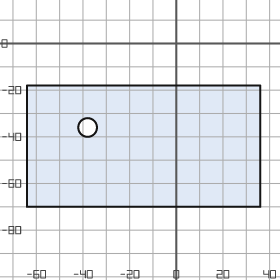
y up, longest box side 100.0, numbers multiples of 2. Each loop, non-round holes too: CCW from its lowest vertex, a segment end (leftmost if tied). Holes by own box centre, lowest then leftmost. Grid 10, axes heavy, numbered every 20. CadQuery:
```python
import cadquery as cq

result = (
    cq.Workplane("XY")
    .moveTo(-64.0, -70.0)
    .lineTo(36.0, -70.0)
    .lineTo(36.0, -18.0)
    .lineTo(-64.0, -18.0)
    .close()
    .moveTo(-38.0, -36.0)
    .circle(4.0)
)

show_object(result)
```